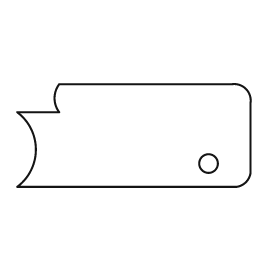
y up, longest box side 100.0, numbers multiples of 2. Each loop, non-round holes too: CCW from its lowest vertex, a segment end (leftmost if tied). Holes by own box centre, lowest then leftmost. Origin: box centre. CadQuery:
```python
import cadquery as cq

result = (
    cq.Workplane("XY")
    .moveTo(-50.0, -22.0)
    .lineTo(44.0, -22.0)
    .threePointArc((48.0, -20.0), (50.0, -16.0))
    .lineTo(50.0, 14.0)
    .threePointArc((48.0, 20.0), (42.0, 22.0))
    .lineTo(-32.0, 22.0)
    .threePointArc((-34.0, 16.0), (-32.0, 10.0))
    .lineTo(-50.0, 10.0)
    .threePointArc((-42.0, -6.0), (-50.0, -22.0))
    .close()
    .moveTo(32.0, -12.0)
    .circle(4.0)
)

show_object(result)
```